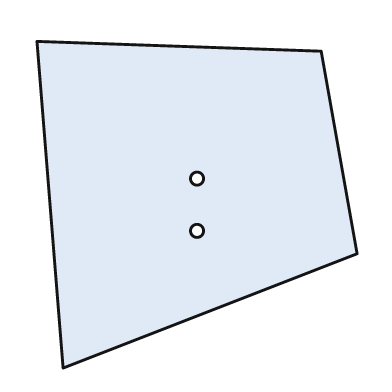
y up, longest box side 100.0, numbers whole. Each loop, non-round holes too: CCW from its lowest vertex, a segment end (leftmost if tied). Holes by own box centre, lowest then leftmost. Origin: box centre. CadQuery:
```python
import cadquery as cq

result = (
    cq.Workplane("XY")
    .moveTo(-41.0, -50.0)
    .lineTo(49.0, -15.0)
    .lineTo(38.0, 47.0)
    .lineTo(-49.0, 50.0)
    .close()
    .moveTo(0.0, -8.0)
    .circle(2.0)
    .moveTo(0.0, 8.0)
    .circle(2.0)
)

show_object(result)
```